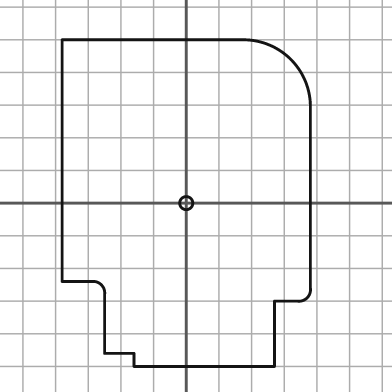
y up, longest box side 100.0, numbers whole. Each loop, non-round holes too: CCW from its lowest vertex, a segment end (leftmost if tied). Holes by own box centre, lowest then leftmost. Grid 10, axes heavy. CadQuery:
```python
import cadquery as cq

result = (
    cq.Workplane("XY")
    .moveTo(-16.0, -50.0)
    .lineTo(27.0, -50.0)
    .lineTo(27.0, -30.0)
    .lineTo(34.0, -30.0)
    .threePointArc((37.0, -29.0), (38.0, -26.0))
    .lineTo(38.0, 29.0)
    .threePointArc((32.0, 44.0), (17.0, 50.0))
    .lineTo(-38.0, 50.0)
    .lineTo(-38.0, -24.0)
    .lineTo(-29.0, -24.0)
    .threePointArc((-26.0, -25.0), (-25.0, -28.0))
    .lineTo(-25.0, -46.0)
    .lineTo(-16.0, -46.0)
    .close()
    .moveTo(0.0, 0.0)
    .circle(2.0)
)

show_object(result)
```